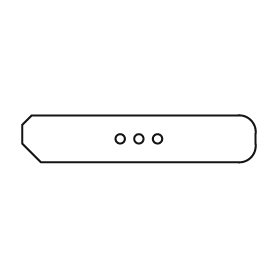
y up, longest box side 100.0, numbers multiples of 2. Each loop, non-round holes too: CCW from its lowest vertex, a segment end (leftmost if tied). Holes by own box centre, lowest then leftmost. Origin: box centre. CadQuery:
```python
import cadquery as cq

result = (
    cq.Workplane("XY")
    .moveTo(-42.0, -10.0)
    .lineTo(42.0, -10.0)
    .threePointArc((48.0, -8.0), (50.0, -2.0))
    .lineTo(50.0, 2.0)
    .threePointArc((48.0, 8.0), (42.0, 10.0))
    .lineTo(-46.0, 10.0)
    .lineTo(-50.0, 6.0)
    .lineTo(-50.0, -2.0)
    .close()
    .moveTo(-8.0, 0.0)
    .circle(2.0)
    .moveTo(0.0, 0.0)
    .circle(2.0)
    .moveTo(8.0, 0.0)
    .circle(2.0)
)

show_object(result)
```